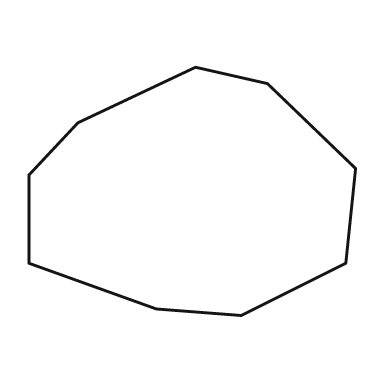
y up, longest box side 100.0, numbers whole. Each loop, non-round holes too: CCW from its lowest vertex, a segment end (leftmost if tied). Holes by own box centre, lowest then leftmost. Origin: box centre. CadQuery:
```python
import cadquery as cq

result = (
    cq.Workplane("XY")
    .moveTo(15.0, -38.0)
    .lineTo(47.0, -22.0)
    .lineTo(50.0, 7.0)
    .lineTo(23.0, 33.0)
    .lineTo(1.0, 38.0)
    .lineTo(-35.0, 21.0)
    .lineTo(-50.0, 5.0)
    .lineTo(-50.0, -22.0)
    .lineTo(-11.0, -36.0)
    .close()
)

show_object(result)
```